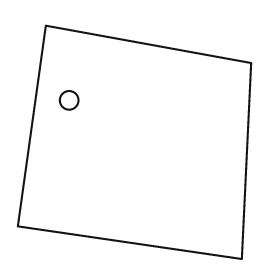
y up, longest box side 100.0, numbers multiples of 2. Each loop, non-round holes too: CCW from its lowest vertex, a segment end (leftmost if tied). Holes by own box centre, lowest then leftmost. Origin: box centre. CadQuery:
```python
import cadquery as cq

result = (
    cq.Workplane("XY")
    .moveTo(46.0, -50.0)
    .lineTo(50.0, 34.0)
    .lineTo(-38.0, 50.0)
    .lineTo(-50.0, -36.0)
    .close()
    .moveTo(-28.0, 18.0)
    .circle(4.0)
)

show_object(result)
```